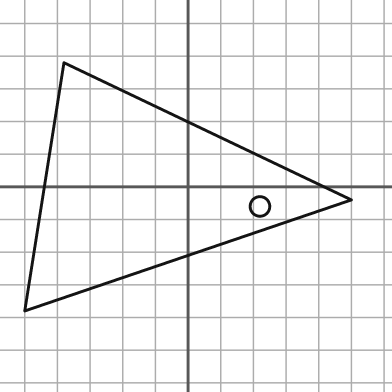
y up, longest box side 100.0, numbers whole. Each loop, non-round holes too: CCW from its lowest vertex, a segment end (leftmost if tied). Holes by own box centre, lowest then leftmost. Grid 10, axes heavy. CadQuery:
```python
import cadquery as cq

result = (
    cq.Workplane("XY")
    .moveTo(-50.0, -38.0)
    .lineTo(50.0, -4.0)
    .lineTo(-38.0, 38.0)
    .close()
    .moveTo(22.0, -6.0)
    .circle(3.0)
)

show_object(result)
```